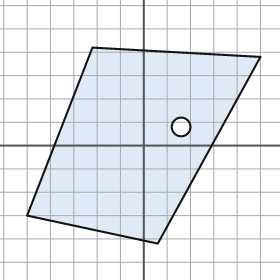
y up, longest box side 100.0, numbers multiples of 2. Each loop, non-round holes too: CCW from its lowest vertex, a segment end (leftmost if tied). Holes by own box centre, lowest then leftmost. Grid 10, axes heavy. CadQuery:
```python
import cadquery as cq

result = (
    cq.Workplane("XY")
    .moveTo(6.0, -42.0)
    .lineTo(50.0, 38.0)
    .lineTo(-22.0, 42.0)
    .lineTo(-50.0, -30.0)
    .close()
    .moveTo(16.0, 8.0)
    .circle(4.0)
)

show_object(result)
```